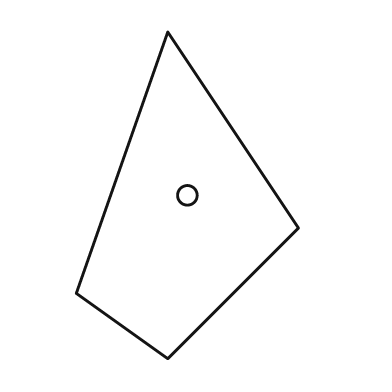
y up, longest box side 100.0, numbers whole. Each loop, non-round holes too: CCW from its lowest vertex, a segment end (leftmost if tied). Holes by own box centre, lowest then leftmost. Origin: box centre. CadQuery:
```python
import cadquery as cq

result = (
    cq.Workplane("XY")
    .moveTo(-6.0, -50.0)
    .lineTo(34.0, -10.0)
    .lineTo(-6.0, 50.0)
    .lineTo(-34.0, -30.0)
    .close()
    .moveTo(0.0, 0.0)
    .circle(3.0)
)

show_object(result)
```